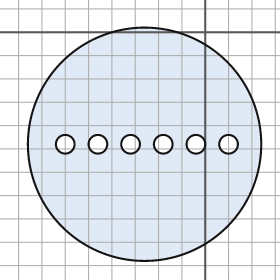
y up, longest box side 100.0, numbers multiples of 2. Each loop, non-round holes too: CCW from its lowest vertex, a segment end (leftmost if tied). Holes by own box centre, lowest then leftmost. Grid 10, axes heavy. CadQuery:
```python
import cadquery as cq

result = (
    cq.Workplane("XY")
    .moveTo(-26.0, -48.0)
    .circle(50.0)
    .moveTo(-60.0, -48.0)
    .circle(4.0)
    .moveTo(-46.0, -48.0)
    .circle(4.0)
    .moveTo(-32.0, -48.0)
    .circle(4.0)
    .moveTo(-18.0, -48.0)
    .circle(4.0)
    .moveTo(-4.0, -48.0)
    .circle(4.0)
    .moveTo(10.0, -48.0)
    .circle(4.0)
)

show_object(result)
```